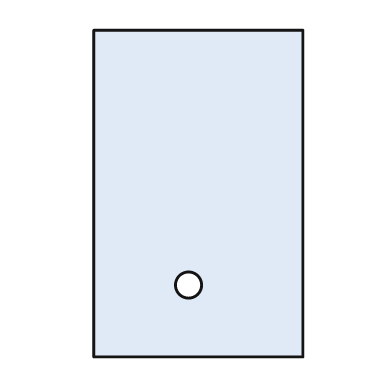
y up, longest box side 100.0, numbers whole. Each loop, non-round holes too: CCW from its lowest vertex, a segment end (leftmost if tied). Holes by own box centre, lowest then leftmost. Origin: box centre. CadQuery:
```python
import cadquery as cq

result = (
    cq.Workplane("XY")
    .moveTo(-32.0, -50.0)
    .lineTo(32.0, -50.0)
    .lineTo(32.0, 50.0)
    .lineTo(-32.0, 50.0)
    .close()
    .moveTo(-3.0, -28.0)
    .circle(4.0)
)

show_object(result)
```